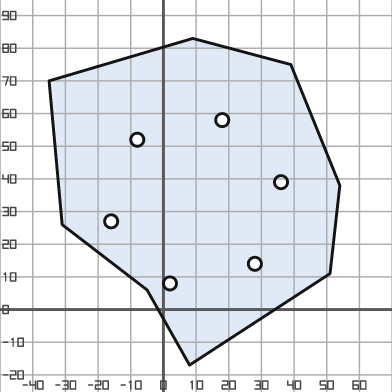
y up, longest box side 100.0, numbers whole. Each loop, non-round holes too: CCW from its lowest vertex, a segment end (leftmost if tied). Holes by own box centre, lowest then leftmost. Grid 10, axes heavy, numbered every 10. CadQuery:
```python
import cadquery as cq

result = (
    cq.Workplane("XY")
    .moveTo(8.0, -17.0)
    .lineTo(51.0, 11.0)
    .lineTo(54.0, 38.0)
    .lineTo(39.0, 75.0)
    .lineTo(9.0, 83.0)
    .lineTo(-35.0, 70.0)
    .lineTo(-31.0, 26.0)
    .lineTo(-5.0, 6.0)
    .close()
    .moveTo(2.0, 8.0)
    .circle(2.0)
    .moveTo(28.0, 14.0)
    .circle(2.0)
    .moveTo(-16.0, 27.0)
    .circle(2.0)
    .moveTo(36.0, 39.0)
    .circle(2.0)
    .moveTo(-8.0, 52.0)
    .circle(2.0)
    .moveTo(18.0, 58.0)
    .circle(2.0)
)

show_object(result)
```